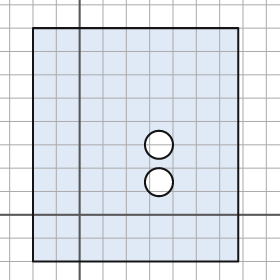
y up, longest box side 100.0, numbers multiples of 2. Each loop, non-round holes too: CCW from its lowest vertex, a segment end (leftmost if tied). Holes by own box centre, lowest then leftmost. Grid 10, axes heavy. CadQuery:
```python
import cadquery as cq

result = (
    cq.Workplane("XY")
    .moveTo(-20.0, -20.0)
    .lineTo(68.0, -20.0)
    .lineTo(68.0, 80.0)
    .lineTo(-20.0, 80.0)
    .close()
    .moveTo(34.0, 14.0)
    .circle(6.0)
    .moveTo(34.0, 30.0)
    .circle(6.0)
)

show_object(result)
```